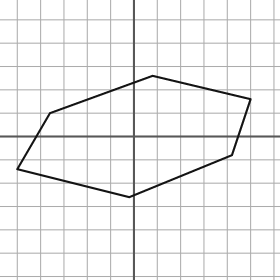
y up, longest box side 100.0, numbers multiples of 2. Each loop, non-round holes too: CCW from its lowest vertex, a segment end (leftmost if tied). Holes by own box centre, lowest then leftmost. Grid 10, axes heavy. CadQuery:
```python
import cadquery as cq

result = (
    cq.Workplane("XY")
    .moveTo(-2.0, -26.0)
    .lineTo(42.0, -8.0)
    .lineTo(50.0, 16.0)
    .lineTo(8.0, 26.0)
    .lineTo(-36.0, 10.0)
    .lineTo(-50.0, -14.0)
    .close()
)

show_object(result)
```